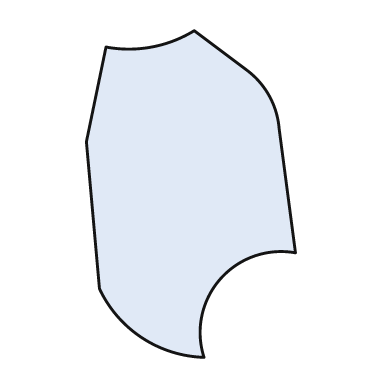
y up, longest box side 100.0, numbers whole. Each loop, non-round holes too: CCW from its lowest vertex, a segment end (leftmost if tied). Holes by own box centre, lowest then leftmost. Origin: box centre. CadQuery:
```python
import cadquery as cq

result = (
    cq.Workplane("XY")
    .moveTo(4.0, -50.0)
    .threePointArc((9.0, -26.0), (32.0, -18.0))
    .lineTo(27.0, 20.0)
    .threePointArc((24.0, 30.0), (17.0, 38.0))
    .lineTo(1.0, 50.0)
    .threePointArc((-12.0, 45.0), (-26.0, 45.0))
    .lineTo(-32.0, 16.0)
    .lineTo(-28.0, -29.0)
    .threePointArc((-15.0, -44.0), (4.0, -50.0))
    .close()
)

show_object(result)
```